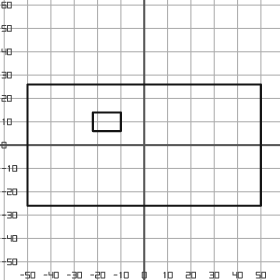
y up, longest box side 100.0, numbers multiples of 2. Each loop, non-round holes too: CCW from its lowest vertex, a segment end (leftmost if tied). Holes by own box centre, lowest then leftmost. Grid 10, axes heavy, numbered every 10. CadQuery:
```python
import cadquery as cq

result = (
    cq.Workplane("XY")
    .moveTo(-50.0, -26.0)
    .lineTo(50.0, -26.0)
    .lineTo(50.0, 26.0)
    .lineTo(-50.0, 26.0)
    .close()
    .moveTo(-22.0, 6.0)
    .lineTo(-10.0, 6.0)
    .lineTo(-10.0, 14.0)
    .lineTo(-22.0, 14.0)
    .close()
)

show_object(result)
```